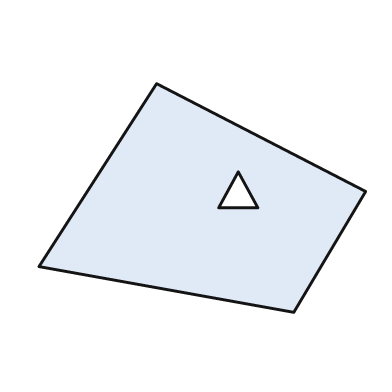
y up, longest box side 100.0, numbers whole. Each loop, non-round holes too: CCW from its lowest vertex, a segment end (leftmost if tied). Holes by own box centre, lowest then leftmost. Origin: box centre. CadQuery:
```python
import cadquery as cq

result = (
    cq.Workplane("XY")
    .moveTo(28.0, -35.0)
    .lineTo(50.0, 2.0)
    .lineTo(-14.0, 35.0)
    .lineTo(-50.0, -21.0)
    .close()
    .moveTo(5.0, -3.0)
    .lineTo(17.0, -3.0)
    .lineTo(11.0, 8.0)
    .close()
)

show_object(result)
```